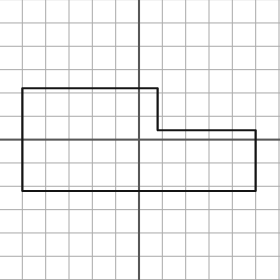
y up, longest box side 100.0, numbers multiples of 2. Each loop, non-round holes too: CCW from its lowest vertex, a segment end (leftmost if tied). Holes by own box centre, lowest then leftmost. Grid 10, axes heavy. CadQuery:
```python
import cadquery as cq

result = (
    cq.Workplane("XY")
    .moveTo(-50.0, -22.0)
    .lineTo(50.0, -22.0)
    .lineTo(50.0, 4.0)
    .lineTo(8.0, 4.0)
    .lineTo(8.0, 22.0)
    .lineTo(-50.0, 22.0)
    .close()
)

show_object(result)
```